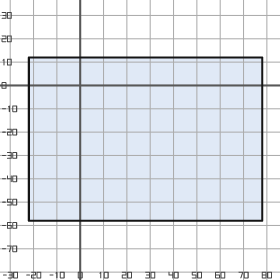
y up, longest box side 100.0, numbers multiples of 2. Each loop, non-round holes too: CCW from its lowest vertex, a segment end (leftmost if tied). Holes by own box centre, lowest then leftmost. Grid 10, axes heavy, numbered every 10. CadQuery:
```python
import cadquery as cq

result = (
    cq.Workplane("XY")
    .moveTo(-22.0, -58.0)
    .lineTo(78.0, -58.0)
    .lineTo(78.0, 12.0)
    .lineTo(-22.0, 12.0)
    .close()
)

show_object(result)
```